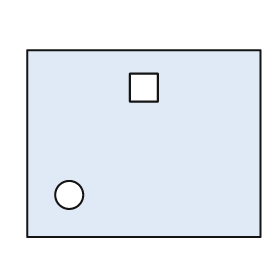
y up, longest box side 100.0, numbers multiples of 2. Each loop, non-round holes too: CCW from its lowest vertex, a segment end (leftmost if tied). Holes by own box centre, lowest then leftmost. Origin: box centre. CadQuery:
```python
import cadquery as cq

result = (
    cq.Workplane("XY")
    .moveTo(-50.0, -40.0)
    .lineTo(50.0, -40.0)
    .lineTo(50.0, 40.0)
    .lineTo(-50.0, 40.0)
    .close()
    .moveTo(-32.0, -22.0)
    .circle(6.0)
    .moveTo(-6.0, 18.0)
    .lineTo(6.0, 18.0)
    .lineTo(6.0, 30.0)
    .lineTo(-6.0, 30.0)
    .close()
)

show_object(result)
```